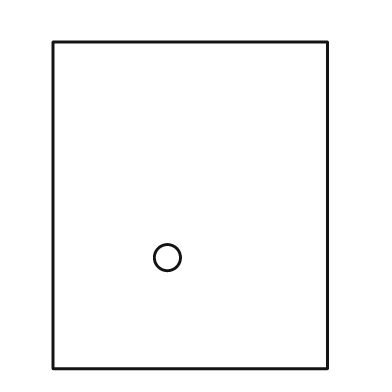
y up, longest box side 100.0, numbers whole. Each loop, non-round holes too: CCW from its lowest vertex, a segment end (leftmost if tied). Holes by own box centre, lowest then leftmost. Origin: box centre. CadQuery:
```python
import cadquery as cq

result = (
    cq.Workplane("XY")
    .moveTo(-42.0, -50.0)
    .lineTo(42.0, -50.0)
    .lineTo(42.0, 50.0)
    .lineTo(-42.0, 50.0)
    .close()
    .moveTo(-7.0, -16.0)
    .circle(4.0)
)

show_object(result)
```